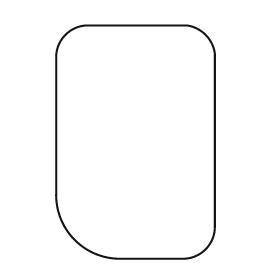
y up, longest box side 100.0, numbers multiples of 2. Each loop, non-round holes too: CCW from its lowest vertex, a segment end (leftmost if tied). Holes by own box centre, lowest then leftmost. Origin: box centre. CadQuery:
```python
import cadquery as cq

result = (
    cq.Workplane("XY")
    .moveTo(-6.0, -50.0)
    .lineTo(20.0, -50.0)
    .threePointArc((30.0, -46.0), (34.0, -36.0))
    .lineTo(34.0, 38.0)
    .threePointArc((30.0, 46.0), (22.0, 50.0))
    .lineTo(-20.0, 50.0)
    .threePointArc((-30.0, 46.0), (-34.0, 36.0))
    .lineTo(-34.0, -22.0)
    .threePointArc((-26.0, -42.0), (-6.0, -50.0))
    .close()
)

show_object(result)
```